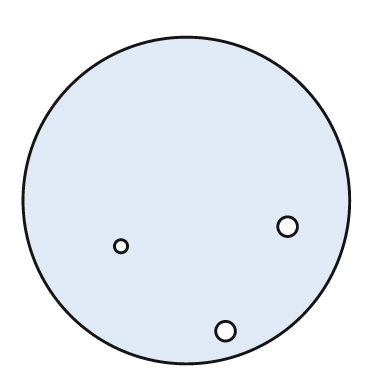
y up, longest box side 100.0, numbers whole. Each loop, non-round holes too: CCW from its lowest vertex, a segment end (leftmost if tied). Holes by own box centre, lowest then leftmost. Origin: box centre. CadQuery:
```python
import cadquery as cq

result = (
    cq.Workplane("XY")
    .moveTo(0.0, 0.0)
    .circle(50.0)
    .moveTo(12.0, -40.0)
    .circle(3.0)
    .moveTo(-20.0, -14.0)
    .circle(2.0)
    .moveTo(31.0, -8.0)
    .circle(3.0)
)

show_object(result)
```